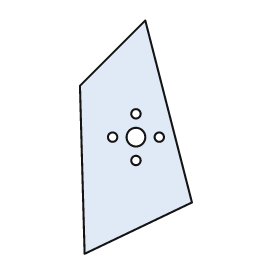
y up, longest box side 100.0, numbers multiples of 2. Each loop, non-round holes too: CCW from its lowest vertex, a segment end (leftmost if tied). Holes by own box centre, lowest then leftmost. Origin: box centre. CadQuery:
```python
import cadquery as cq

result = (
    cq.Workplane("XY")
    .moveTo(-22.0, -50.0)
    .lineTo(24.0, -28.0)
    .lineTo(4.0, 50.0)
    .lineTo(-24.0, 22.0)
    .close()
    .moveTo(0.0, -10.0)
    .circle(2.0)
    .moveTo(-10.0, 0.0)
    .circle(2.0)
    .moveTo(0.0, 0.0)
    .circle(4.0)
    .moveTo(10.0, 0.0)
    .circle(2.0)
    .moveTo(0.0, 10.0)
    .circle(2.0)
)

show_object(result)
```